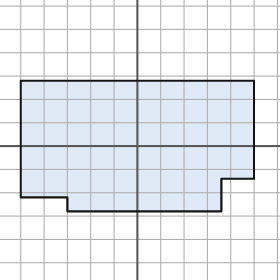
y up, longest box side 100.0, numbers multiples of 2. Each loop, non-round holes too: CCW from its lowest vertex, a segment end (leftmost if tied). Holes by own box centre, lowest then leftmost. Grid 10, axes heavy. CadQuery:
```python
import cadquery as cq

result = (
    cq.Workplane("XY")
    .moveTo(-30.0, -28.0)
    .lineTo(36.0, -28.0)
    .lineTo(36.0, -14.0)
    .lineTo(50.0, -14.0)
    .lineTo(50.0, 28.0)
    .lineTo(-50.0, 28.0)
    .lineTo(-50.0, -22.0)
    .lineTo(-30.0, -22.0)
    .close()
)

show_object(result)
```